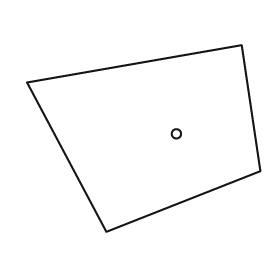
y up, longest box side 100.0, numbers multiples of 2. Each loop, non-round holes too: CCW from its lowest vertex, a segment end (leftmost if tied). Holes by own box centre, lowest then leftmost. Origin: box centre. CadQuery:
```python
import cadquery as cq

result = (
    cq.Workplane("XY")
    .moveTo(-16.0, -40.0)
    .lineTo(50.0, -14.0)
    .lineTo(42.0, 40.0)
    .lineTo(-50.0, 24.0)
    .close()
    .moveTo(14.0, 2.0)
    .circle(2.0)
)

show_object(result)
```